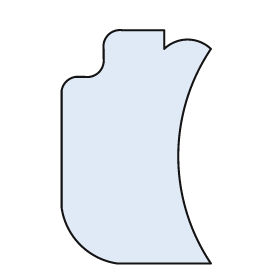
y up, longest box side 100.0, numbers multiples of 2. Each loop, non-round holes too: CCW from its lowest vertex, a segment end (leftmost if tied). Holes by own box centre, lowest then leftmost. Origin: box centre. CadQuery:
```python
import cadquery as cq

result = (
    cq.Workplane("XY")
    .moveTo(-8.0, -50.0)
    .lineTo(32.0, -50.0)
    .threePointArc((18.0, -4.0), (32.0, 42.0))
    .threePointArc((22.0, 46.0), (12.0, 42.0))
    .lineTo(12.0, 50.0)
    .lineTo(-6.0, 50.0)
    .threePointArc((-12.0, 48.0), (-14.0, 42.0))
    .lineTo(-14.0, 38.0)
    .threePointArc((-16.0, 32.0), (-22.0, 30.0))
    .lineTo(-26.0, 30.0)
    .threePointArc((-30.0, 28.0), (-32.0, 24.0))
    .lineTo(-32.0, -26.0)
    .threePointArc((-24.0, -42.0), (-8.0, -50.0))
    .close()
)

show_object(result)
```